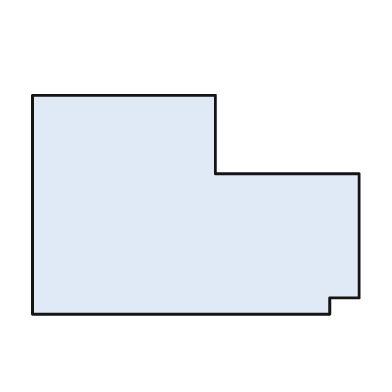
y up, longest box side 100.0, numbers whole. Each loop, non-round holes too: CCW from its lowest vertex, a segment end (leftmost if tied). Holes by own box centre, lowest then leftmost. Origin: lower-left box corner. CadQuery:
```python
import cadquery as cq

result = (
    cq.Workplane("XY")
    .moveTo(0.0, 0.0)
    .lineTo(91.0, 0.0)
    .lineTo(91.0, 5.0)
    .lineTo(100.0, 5.0)
    .lineTo(100.0, 43.0)
    .lineTo(56.0, 43.0)
    .lineTo(56.0, 67.0)
    .lineTo(0.0, 67.0)
    .close()
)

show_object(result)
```